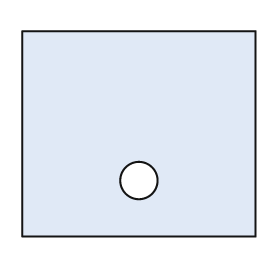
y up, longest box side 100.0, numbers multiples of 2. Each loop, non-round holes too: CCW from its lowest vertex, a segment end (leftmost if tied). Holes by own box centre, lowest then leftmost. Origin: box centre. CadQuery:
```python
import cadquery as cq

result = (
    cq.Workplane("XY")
    .moveTo(-50.0, -44.0)
    .lineTo(50.0, -44.0)
    .lineTo(50.0, 44.0)
    .lineTo(-50.0, 44.0)
    .close()
    .moveTo(0.0, -20.0)
    .circle(8.0)
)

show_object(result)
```